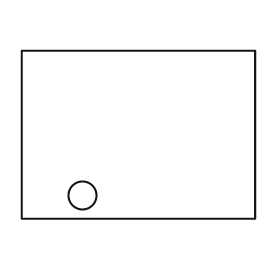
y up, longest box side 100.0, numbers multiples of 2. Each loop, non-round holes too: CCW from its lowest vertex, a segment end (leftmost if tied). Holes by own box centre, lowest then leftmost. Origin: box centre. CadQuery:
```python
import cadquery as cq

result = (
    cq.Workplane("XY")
    .moveTo(-50.0, -36.0)
    .lineTo(50.0, -36.0)
    .lineTo(50.0, 36.0)
    .lineTo(-50.0, 36.0)
    .close()
    .moveTo(-24.0, -26.0)
    .circle(6.0)
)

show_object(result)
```